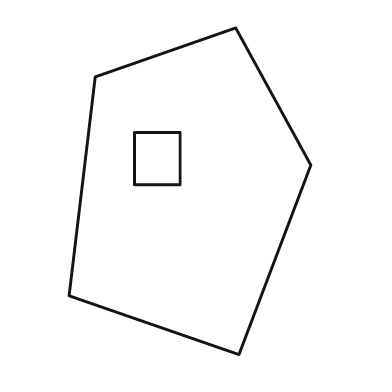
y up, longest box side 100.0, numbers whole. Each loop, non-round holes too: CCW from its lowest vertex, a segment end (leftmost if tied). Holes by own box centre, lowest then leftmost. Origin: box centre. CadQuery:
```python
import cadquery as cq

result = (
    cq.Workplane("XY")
    .moveTo(15.0, -50.0)
    .lineTo(37.0, 8.0)
    .lineTo(14.0, 50.0)
    .lineTo(-29.0, 35.0)
    .lineTo(-37.0, -32.0)
    .close()
    .moveTo(-17.0, 2.0)
    .lineTo(-3.0, 2.0)
    .lineTo(-3.0, 18.0)
    .lineTo(-17.0, 18.0)
    .close()
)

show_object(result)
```